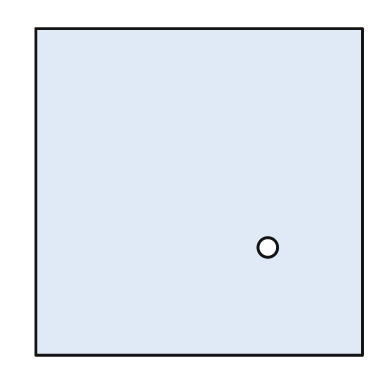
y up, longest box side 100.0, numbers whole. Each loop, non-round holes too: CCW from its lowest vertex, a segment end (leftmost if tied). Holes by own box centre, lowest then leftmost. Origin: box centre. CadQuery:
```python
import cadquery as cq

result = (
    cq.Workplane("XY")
    .moveTo(-50.0, -50.0)
    .lineTo(50.0, -50.0)
    .lineTo(50.0, 50.0)
    .lineTo(-50.0, 50.0)
    .close()
    .moveTo(21.0, -17.0)
    .circle(3.0)
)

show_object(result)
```